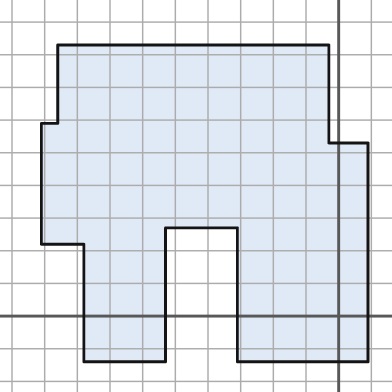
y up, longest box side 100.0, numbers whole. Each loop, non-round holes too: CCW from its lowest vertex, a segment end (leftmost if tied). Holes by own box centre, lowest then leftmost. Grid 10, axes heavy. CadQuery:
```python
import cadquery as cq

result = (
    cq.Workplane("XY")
    .moveTo(-78.0, -14.0)
    .lineTo(-53.0, -14.0)
    .lineTo(-53.0, 27.0)
    .lineTo(-31.0, 27.0)
    .lineTo(-31.0, -14.0)
    .lineTo(9.0, -14.0)
    .lineTo(9.0, 53.0)
    .lineTo(-3.0, 53.0)
    .lineTo(-3.0, 83.0)
    .lineTo(-86.0, 83.0)
    .lineTo(-86.0, 59.0)
    .lineTo(-91.0, 59.0)
    .lineTo(-91.0, 22.0)
    .lineTo(-78.0, 22.0)
    .close()
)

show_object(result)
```